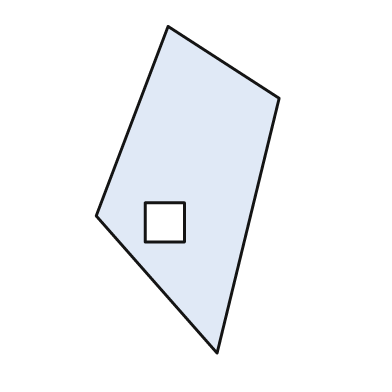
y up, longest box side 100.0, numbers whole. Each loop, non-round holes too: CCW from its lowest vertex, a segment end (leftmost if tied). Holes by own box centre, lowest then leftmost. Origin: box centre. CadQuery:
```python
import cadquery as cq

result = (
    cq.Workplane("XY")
    .moveTo(9.0, -50.0)
    .lineTo(28.0, 28.0)
    .lineTo(-6.0, 50.0)
    .lineTo(-28.0, -8.0)
    .close()
    .moveTo(-13.0, -16.0)
    .lineTo(-1.0, -16.0)
    .lineTo(-1.0, -4.0)
    .lineTo(-13.0, -4.0)
    .close()
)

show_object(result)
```